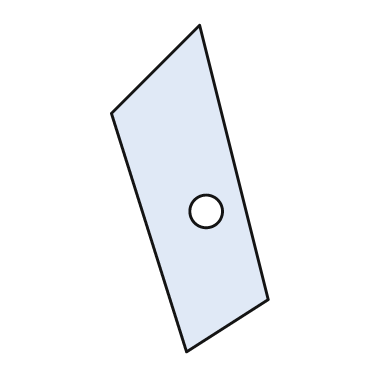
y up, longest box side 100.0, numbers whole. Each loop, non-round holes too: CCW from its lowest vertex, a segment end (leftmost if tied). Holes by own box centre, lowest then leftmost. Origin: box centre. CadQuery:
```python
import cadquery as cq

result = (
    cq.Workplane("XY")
    .moveTo(-1.0, -50.0)
    .lineTo(24.0, -34.0)
    .lineTo(3.0, 50.0)
    .lineTo(-24.0, 23.0)
    .close()
    .moveTo(5.0, -7.0)
    .circle(5.0)
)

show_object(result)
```